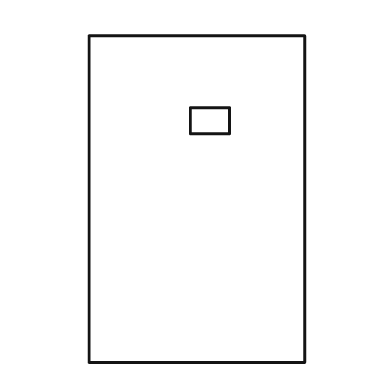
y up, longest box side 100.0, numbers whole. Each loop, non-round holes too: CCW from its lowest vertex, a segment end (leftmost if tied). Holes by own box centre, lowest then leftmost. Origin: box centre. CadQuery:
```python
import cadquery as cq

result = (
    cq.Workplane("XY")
    .moveTo(-33.0, -50.0)
    .lineTo(33.0, -50.0)
    .lineTo(33.0, 50.0)
    .lineTo(-33.0, 50.0)
    .close()
    .moveTo(-2.0, 20.0)
    .lineTo(10.0, 20.0)
    .lineTo(10.0, 28.0)
    .lineTo(-2.0, 28.0)
    .close()
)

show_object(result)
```